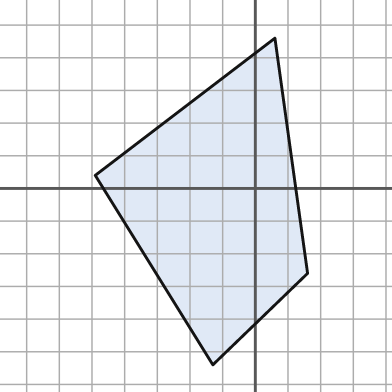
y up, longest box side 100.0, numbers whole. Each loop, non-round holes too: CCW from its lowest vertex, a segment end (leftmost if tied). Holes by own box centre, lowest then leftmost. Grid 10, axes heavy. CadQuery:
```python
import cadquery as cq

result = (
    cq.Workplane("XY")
    .moveTo(-13.0, -54.0)
    .lineTo(16.0, -26.0)
    .lineTo(6.0, 46.0)
    .lineTo(-49.0, 4.0)
    .close()
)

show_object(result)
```